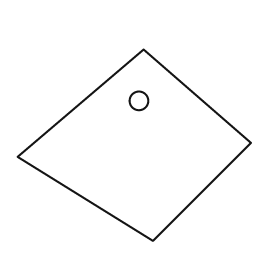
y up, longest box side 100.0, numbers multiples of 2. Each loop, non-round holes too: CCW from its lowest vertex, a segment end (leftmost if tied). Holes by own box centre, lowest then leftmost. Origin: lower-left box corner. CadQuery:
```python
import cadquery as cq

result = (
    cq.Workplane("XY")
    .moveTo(58.0, 0.0)
    .lineTo(100.0, 42.0)
    .lineTo(54.0, 82.0)
    .lineTo(0.0, 36.0)
    .close()
    .moveTo(52.0, 60.0)
    .circle(4.0)
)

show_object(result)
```